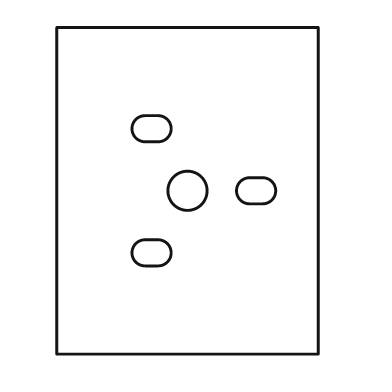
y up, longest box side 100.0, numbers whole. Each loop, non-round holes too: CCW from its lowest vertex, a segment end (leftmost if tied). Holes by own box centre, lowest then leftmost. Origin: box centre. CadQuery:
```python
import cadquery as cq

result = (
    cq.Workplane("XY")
    .moveTo(-40.0, -50.0)
    .lineTo(40.0, -50.0)
    .lineTo(40.0, 50.0)
    .lineTo(-40.0, 50.0)
    .close()
    .moveTo(-13.0, -23.0)
    .lineTo(-9.0, -23.0)
    .threePointArc((-5.0, -19.0), (-9.0, -15.0))
    .lineTo(-13.0, -15.0)
    .threePointArc((-17.0, -19.0), (-13.0, -23.0))
    .close()
    .moveTo(0.0, 0.0)
    .circle(6.0)
    .moveTo(19.0, -4.0)
    .lineTo(23.0, -4.0)
    .threePointArc((27.0, 0.0), (23.0, 4.0))
    .lineTo(19.0, 4.0)
    .threePointArc((15.0, 0.0), (19.0, -4.0))
    .close()
    .moveTo(-13.0, 15.0)
    .lineTo(-9.0, 15.0)
    .threePointArc((-5.0, 19.0), (-9.0, 23.0))
    .lineTo(-13.0, 23.0)
    .threePointArc((-17.0, 19.0), (-13.0, 15.0))
    .close()
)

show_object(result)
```